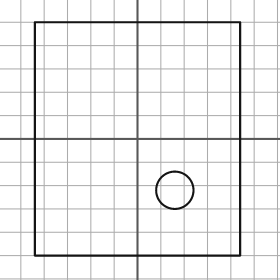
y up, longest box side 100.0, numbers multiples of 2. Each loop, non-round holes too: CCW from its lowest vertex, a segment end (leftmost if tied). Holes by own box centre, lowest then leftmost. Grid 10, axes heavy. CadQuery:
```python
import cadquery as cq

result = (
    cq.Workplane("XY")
    .moveTo(-44.0, -50.0)
    .lineTo(44.0, -50.0)
    .lineTo(44.0, 50.0)
    .lineTo(-44.0, 50.0)
    .close()
    .moveTo(16.0, -22.0)
    .circle(8.0)
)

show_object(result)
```